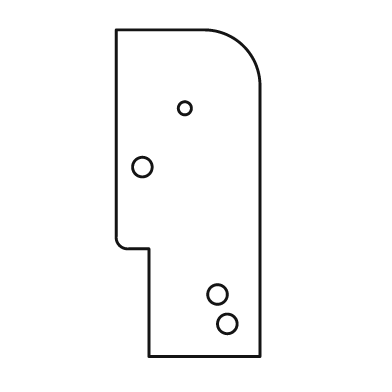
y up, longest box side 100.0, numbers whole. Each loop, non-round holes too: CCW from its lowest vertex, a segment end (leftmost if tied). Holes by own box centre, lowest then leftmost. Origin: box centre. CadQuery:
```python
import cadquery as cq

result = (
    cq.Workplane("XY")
    .moveTo(-12.0, -50.0)
    .lineTo(22.0, -50.0)
    .lineTo(22.0, 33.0)
    .threePointArc((17.0, 45.0), (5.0, 50.0))
    .lineTo(-22.0, 50.0)
    .lineTo(-22.0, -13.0)
    .threePointArc((-21.0, -16.0), (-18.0, -17.0))
    .lineTo(-12.0, -17.0)
    .close()
    .moveTo(12.0, -40.0)
    .circle(3.0)
    .moveTo(9.0, -31.0)
    .circle(3.0)
    .moveTo(-14.0, 8.0)
    .circle(3.0)
    .moveTo(-1.0, 26.0)
    .circle(2.0)
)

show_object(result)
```